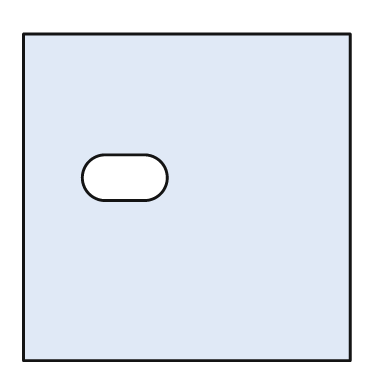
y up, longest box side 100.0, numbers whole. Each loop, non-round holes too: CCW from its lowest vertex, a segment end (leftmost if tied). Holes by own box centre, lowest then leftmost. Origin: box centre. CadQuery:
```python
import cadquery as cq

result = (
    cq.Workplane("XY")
    .moveTo(-50.0, -50.0)
    .lineTo(50.0, -50.0)
    .lineTo(50.0, 50.0)
    .lineTo(-50.0, 50.0)
    .close()
    .moveTo(-25.0, -1.0)
    .lineTo(-13.0, -1.0)
    .threePointArc((-6.0, 6.0), (-13.0, 13.0))
    .lineTo(-25.0, 13.0)
    .threePointArc((-32.0, 6.0), (-25.0, -1.0))
    .close()
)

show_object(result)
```